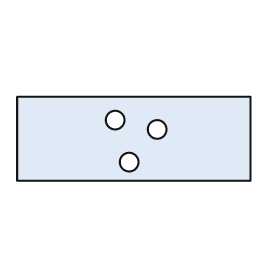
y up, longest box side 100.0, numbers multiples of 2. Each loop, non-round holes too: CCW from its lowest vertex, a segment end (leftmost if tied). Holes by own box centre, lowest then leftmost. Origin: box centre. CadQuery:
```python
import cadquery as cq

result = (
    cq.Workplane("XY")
    .moveTo(-50.0, -18.0)
    .lineTo(50.0, -18.0)
    .lineTo(50.0, 18.0)
    .lineTo(-50.0, 18.0)
    .close()
    .moveTo(-2.0, -10.0)
    .circle(4.0)
    .moveTo(10.0, 4.0)
    .circle(4.0)
    .moveTo(-8.0, 8.0)
    .circle(4.0)
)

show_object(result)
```